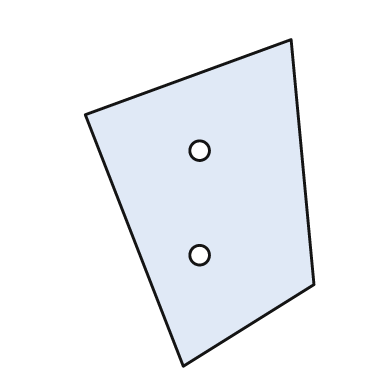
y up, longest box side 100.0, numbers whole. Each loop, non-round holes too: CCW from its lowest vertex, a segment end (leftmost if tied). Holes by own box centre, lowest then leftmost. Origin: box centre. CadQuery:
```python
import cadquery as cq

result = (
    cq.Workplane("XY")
    .moveTo(-5.0, -50.0)
    .lineTo(35.0, -25.0)
    .lineTo(28.0, 50.0)
    .lineTo(-35.0, 27.0)
    .close()
    .moveTo(0.0, -16.0)
    .circle(3.0)
    .moveTo(0.0, 16.0)
    .circle(3.0)
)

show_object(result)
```